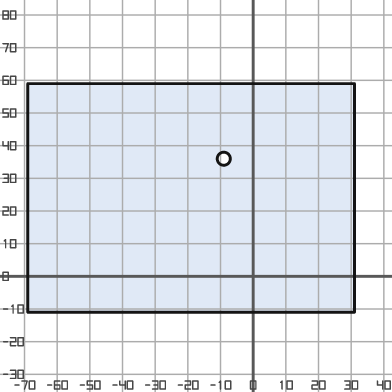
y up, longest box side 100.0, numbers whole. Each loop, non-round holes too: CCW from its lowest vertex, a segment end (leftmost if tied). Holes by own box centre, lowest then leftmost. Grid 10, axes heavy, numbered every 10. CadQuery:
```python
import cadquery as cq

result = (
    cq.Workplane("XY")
    .moveTo(-69.0, -11.0)
    .lineTo(31.0, -11.0)
    .lineTo(31.0, 59.0)
    .lineTo(-69.0, 59.0)
    .close()
    .moveTo(-9.0, 36.0)
    .circle(2.0)
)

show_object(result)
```